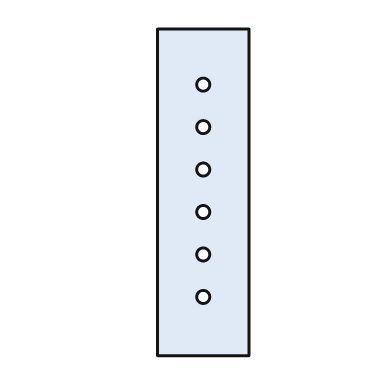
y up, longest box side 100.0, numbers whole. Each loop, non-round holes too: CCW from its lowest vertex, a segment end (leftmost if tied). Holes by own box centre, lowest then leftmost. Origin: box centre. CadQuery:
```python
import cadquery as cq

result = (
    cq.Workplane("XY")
    .moveTo(-14.0, -50.0)
    .lineTo(14.0, -50.0)
    .lineTo(14.0, 50.0)
    .lineTo(-14.0, 50.0)
    .close()
    .moveTo(0.0, -32.0)
    .circle(2.0)
    .moveTo(0.0, -19.0)
    .circle(2.0)
    .moveTo(0.0, -6.0)
    .circle(2.0)
    .moveTo(0.0, 7.0)
    .circle(2.0)
    .moveTo(0.0, 20.0)
    .circle(2.0)
    .moveTo(0.0, 33.0)
    .circle(2.0)
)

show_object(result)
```